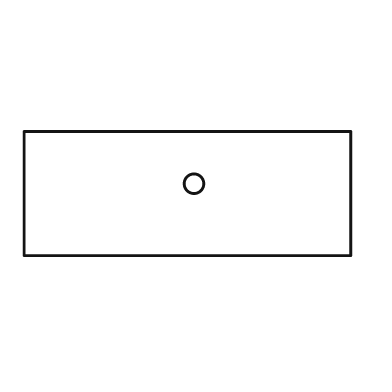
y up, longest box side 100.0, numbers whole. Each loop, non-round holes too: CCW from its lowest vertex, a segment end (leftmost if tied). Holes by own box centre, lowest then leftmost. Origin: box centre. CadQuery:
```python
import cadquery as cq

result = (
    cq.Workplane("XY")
    .moveTo(-50.0, -19.0)
    .lineTo(50.0, -19.0)
    .lineTo(50.0, 19.0)
    .lineTo(-50.0, 19.0)
    .close()
    .moveTo(2.0, 3.0)
    .circle(3.0)
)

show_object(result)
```